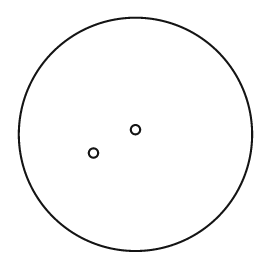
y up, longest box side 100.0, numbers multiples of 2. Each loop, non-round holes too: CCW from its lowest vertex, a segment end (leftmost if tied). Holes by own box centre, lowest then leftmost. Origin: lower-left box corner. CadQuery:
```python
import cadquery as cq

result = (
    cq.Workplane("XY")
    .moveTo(50.0, 50.0)
    .circle(50.0)
    .moveTo(32.0, 42.0)
    .circle(2.0)
    .moveTo(50.0, 52.0)
    .circle(2.0)
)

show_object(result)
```